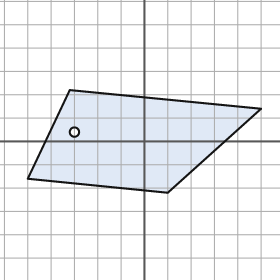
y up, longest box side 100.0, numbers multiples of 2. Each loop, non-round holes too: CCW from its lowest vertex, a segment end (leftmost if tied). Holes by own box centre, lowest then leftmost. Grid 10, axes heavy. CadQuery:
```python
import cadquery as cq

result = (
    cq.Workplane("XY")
    .moveTo(10.0, -22.0)
    .lineTo(50.0, 14.0)
    .lineTo(-32.0, 22.0)
    .lineTo(-50.0, -16.0)
    .close()
    .moveTo(-30.0, 4.0)
    .circle(2.0)
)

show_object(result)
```